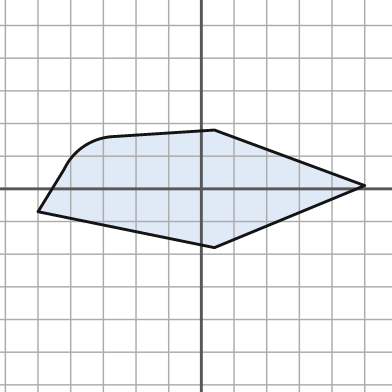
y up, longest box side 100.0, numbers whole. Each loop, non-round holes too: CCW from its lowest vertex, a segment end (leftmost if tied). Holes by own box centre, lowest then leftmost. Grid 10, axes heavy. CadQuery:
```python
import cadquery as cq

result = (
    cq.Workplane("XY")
    .moveTo(4.0, -18.0)
    .lineTo(50.0, 1.0)
    .lineTo(4.0, 18.0)
    .lineTo(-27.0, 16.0)
    .threePointArc((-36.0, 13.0), (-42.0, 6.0))
    .lineTo(-50.0, -7.0)
    .close()
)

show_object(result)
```